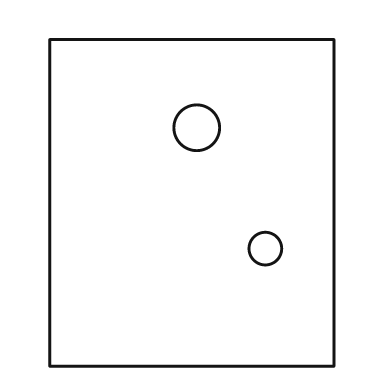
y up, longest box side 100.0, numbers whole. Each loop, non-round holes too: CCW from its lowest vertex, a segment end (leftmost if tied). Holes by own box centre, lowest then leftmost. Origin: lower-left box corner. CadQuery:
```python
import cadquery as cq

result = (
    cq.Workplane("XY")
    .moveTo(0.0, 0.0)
    .lineTo(87.0, 0.0)
    .lineTo(87.0, 100.0)
    .lineTo(0.0, 100.0)
    .close()
    .moveTo(66.0, 36.0)
    .circle(5.0)
    .moveTo(45.0, 73.0)
    .circle(7.0)
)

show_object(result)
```